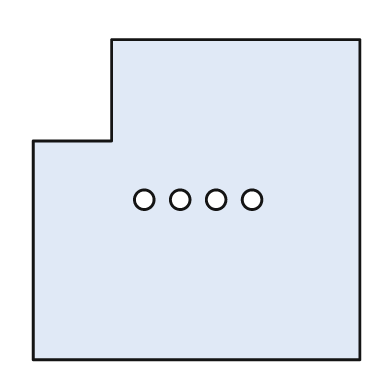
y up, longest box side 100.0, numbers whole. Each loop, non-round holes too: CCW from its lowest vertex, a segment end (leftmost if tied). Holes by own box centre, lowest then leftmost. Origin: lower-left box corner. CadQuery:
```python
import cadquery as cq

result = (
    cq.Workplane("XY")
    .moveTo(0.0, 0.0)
    .lineTo(100.0, 0.0)
    .lineTo(100.0, 98.0)
    .lineTo(24.0, 98.0)
    .lineTo(24.0, 67.0)
    .lineTo(0.0, 67.0)
    .close()
    .moveTo(34.0, 49.0)
    .circle(3.0)
    .moveTo(45.0, 49.0)
    .circle(3.0)
    .moveTo(56.0, 49.0)
    .circle(3.0)
    .moveTo(67.0, 49.0)
    .circle(3.0)
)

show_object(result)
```